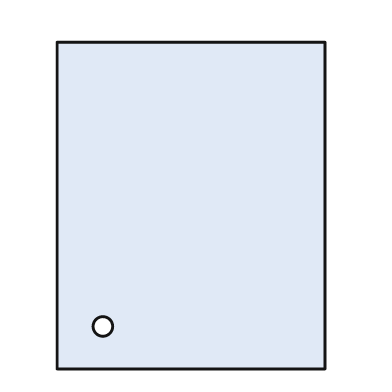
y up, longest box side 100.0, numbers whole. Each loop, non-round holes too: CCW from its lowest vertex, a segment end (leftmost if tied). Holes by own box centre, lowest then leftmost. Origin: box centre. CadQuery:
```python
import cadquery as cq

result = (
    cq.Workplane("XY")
    .moveTo(-41.0, -50.0)
    .lineTo(41.0, -50.0)
    .lineTo(41.0, 50.0)
    .lineTo(-41.0, 50.0)
    .close()
    .moveTo(-27.0, -37.0)
    .circle(3.0)
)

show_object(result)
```